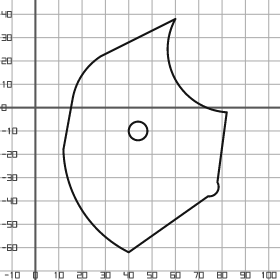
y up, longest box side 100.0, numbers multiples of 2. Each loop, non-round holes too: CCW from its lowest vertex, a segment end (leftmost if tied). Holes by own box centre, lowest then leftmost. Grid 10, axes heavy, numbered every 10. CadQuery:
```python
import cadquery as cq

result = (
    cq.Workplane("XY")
    .moveTo(40.0, -62.0)
    .lineTo(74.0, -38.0)
    .threePointArc((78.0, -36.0), (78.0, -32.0))
    .lineTo(82.0, -2.0)
    .threePointArc((60.0, 12.0), (60.0, 38.0))
    .lineTo(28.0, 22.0)
    .threePointArc((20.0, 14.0), (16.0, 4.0))
    .lineTo(12.0, -18.0)
    .threePointArc((20.0, -44.0), (40.0, -62.0))
    .close()
    .moveTo(44.0, -10.0)
    .circle(4.0)
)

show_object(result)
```